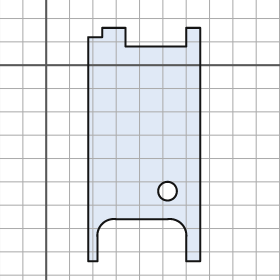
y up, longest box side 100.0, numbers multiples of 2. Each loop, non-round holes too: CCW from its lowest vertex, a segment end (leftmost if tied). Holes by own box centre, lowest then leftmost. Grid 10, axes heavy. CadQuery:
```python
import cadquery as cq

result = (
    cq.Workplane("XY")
    .moveTo(18.0, -84.0)
    .lineTo(22.0, -84.0)
    .lineTo(22.0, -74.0)
    .threePointArc((24.0, -68.0), (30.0, -66.0))
    .lineTo(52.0, -66.0)
    .threePointArc((58.0, -68.0), (60.0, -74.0))
    .lineTo(60.0, -84.0)
    .lineTo(66.0, -84.0)
    .lineTo(66.0, 16.0)
    .lineTo(60.0, 16.0)
    .lineTo(60.0, 8.0)
    .lineTo(34.0, 8.0)
    .lineTo(34.0, 16.0)
    .lineTo(24.0, 16.0)
    .lineTo(24.0, 12.0)
    .lineTo(18.0, 12.0)
    .close()
    .moveTo(52.0, -54.0)
    .circle(4.0)
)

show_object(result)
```